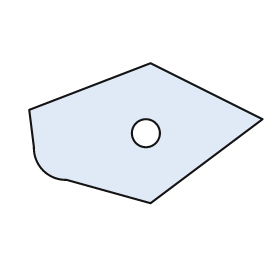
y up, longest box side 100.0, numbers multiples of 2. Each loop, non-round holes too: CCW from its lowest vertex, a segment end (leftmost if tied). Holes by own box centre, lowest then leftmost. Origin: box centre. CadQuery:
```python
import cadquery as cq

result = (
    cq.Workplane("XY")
    .moveTo(2.0, -30.0)
    .lineTo(50.0, 6.0)
    .lineTo(2.0, 30.0)
    .lineTo(-50.0, 10.0)
    .lineTo(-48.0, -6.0)
    .threePointArc((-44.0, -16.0), (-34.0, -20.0))
    .close()
    .moveTo(0.0, 0.0)
    .circle(6.0)
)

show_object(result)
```